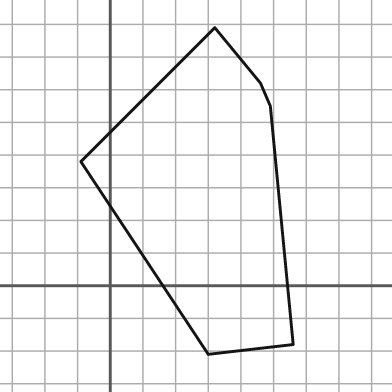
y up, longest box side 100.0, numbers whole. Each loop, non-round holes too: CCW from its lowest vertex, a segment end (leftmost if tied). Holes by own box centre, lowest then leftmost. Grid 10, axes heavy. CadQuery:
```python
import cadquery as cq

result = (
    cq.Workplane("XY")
    .moveTo(30.0, -21.0)
    .lineTo(56.0, -18.0)
    .lineTo(49.0, 55.0)
    .lineTo(46.0, 62.0)
    .lineTo(32.0, 79.0)
    .lineTo(-9.0, 38.0)
    .close()
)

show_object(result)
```